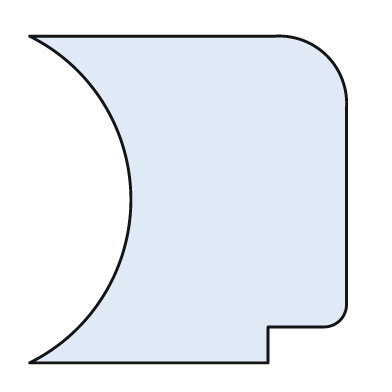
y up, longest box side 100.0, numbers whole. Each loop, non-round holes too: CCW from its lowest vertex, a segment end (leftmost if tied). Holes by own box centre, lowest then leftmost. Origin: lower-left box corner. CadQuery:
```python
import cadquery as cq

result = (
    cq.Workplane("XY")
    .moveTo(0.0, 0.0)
    .lineTo(73.0, 0.0)
    .lineTo(73.0, 11.0)
    .lineTo(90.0, 11.0)
    .threePointArc((95.0, 13.0), (97.0, 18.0))
    .lineTo(97.0, 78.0)
    .threePointArc((91.0, 94.0), (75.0, 100.0))
    .lineTo(0.0, 100.0)
    .threePointArc((31.0, 50.0), (0.0, 0.0))
    .close()
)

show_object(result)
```